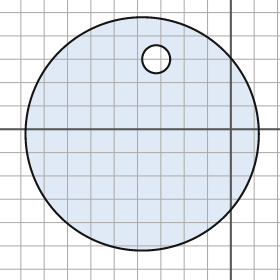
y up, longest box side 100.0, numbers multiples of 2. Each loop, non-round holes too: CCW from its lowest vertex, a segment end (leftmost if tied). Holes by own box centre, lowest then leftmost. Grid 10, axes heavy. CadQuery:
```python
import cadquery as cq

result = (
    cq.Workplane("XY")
    .moveTo(-38.0, -2.0)
    .circle(50.0)
    .moveTo(-32.0, 30.0)
    .circle(6.0)
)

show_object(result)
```